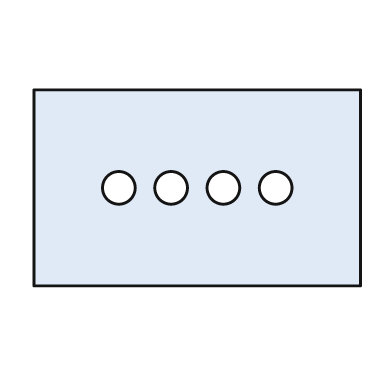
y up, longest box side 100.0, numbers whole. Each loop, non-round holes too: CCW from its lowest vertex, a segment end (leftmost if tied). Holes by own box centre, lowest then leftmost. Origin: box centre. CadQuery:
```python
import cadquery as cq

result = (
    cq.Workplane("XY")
    .moveTo(-50.0, -30.0)
    .lineTo(50.0, -30.0)
    .lineTo(50.0, 30.0)
    .lineTo(-50.0, 30.0)
    .close()
    .moveTo(-24.0, 0.0)
    .circle(5.0)
    .moveTo(-8.0, 0.0)
    .circle(5.0)
    .moveTo(8.0, 0.0)
    .circle(5.0)
    .moveTo(24.0, 0.0)
    .circle(5.0)
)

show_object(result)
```